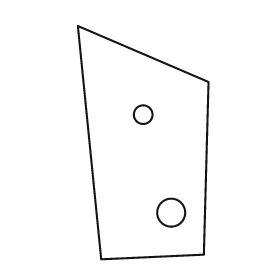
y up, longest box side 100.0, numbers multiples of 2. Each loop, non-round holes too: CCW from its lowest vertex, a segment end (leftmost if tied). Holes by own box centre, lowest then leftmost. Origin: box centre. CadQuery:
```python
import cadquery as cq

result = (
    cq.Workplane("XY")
    .moveTo(-18.0, -50.0)
    .lineTo(26.0, -48.0)
    .lineTo(28.0, 26.0)
    .lineTo(-28.0, 50.0)
    .close()
    .moveTo(12.0, -30.0)
    .circle(6.0)
    .moveTo(0.0, 12.0)
    .circle(4.0)
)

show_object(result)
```